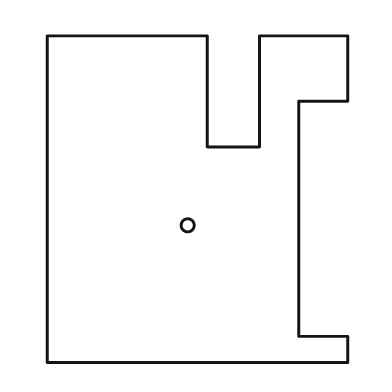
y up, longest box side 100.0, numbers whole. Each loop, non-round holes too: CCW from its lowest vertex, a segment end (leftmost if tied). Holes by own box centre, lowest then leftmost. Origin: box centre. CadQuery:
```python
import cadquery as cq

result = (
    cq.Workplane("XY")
    .moveTo(-46.0, -50.0)
    .lineTo(46.0, -50.0)
    .lineTo(46.0, -42.0)
    .lineTo(31.0, -42.0)
    .lineTo(31.0, 30.0)
    .lineTo(46.0, 30.0)
    .lineTo(46.0, 50.0)
    .lineTo(19.0, 50.0)
    .lineTo(19.0, 16.0)
    .lineTo(3.0, 16.0)
    .lineTo(3.0, 50.0)
    .lineTo(-46.0, 50.0)
    .close()
    .moveTo(-3.0, -8.0)
    .circle(2.0)
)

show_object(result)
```